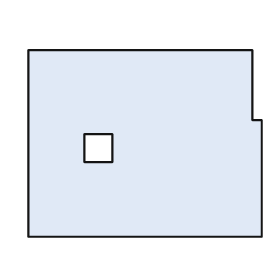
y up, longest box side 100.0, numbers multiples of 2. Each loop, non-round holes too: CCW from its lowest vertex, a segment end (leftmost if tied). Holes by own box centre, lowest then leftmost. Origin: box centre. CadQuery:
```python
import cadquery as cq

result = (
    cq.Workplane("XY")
    .moveTo(-50.0, -40.0)
    .lineTo(50.0, -40.0)
    .lineTo(50.0, 10.0)
    .lineTo(46.0, 10.0)
    .lineTo(46.0, 40.0)
    .lineTo(-50.0, 40.0)
    .close()
    .moveTo(-26.0, -8.0)
    .lineTo(-14.0, -8.0)
    .lineTo(-14.0, 4.0)
    .lineTo(-26.0, 4.0)
    .close()
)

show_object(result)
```